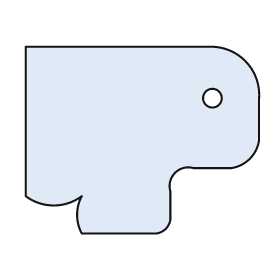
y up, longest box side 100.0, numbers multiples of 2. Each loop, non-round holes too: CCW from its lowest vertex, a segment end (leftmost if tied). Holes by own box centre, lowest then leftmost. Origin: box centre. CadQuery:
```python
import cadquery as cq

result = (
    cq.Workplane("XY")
    .moveTo(-26.0, -40.0)
    .lineTo(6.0, -40.0)
    .threePointArc((10.0, -38.0), (12.0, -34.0))
    .lineTo(12.0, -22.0)
    .threePointArc((14.0, -14.0), (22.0, -12.0))
    .lineTo(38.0, -12.0)
    .threePointArc((46.0, -8.0), (50.0, 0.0))
    .lineTo(50.0, 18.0)
    .threePointArc((44.0, 34.0), (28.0, 40.0))
    .lineTo(-50.0, 40.0)
    .lineTo(-50.0, -24.0)
    .threePointArc((-38.0, -28.0), (-26.0, -24.0))
    .threePointArc((-28.0, -32.0), (-26.0, -40.0))
    .close()
    .moveTo(30.0, 18.0)
    .circle(4.0)
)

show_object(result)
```